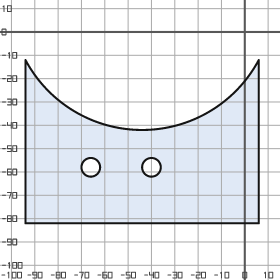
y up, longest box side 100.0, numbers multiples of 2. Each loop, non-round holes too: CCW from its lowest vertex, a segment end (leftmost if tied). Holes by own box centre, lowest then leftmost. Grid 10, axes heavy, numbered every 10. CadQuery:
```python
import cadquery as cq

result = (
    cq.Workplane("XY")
    .moveTo(-94.0, -82.0)
    .lineTo(6.0, -82.0)
    .lineTo(6.0, -12.0)
    .threePointArc((-44.0, -42.0), (-94.0, -12.0))
    .close()
    .moveTo(-66.0, -58.0)
    .circle(4.0)
    .moveTo(-40.0, -58.0)
    .circle(4.0)
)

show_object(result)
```